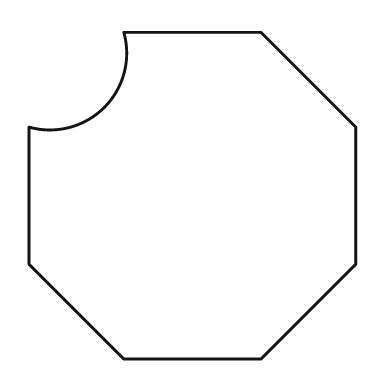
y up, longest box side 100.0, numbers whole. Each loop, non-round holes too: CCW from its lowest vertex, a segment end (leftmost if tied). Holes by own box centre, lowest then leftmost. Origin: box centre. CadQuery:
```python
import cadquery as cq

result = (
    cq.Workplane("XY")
    .moveTo(-21.0, -50.0)
    .lineTo(21.0, -50.0)
    .lineTo(50.0, -21.0)
    .lineTo(50.0, 21.0)
    .lineTo(21.0, 50.0)
    .lineTo(-21.0, 50.0)
    .threePointArc((-27.0, 27.0), (-50.0, 21.0))
    .lineTo(-50.0, -21.0)
    .close()
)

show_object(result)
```